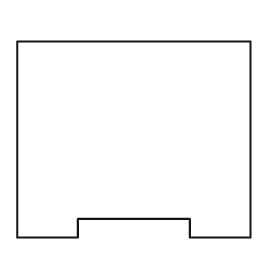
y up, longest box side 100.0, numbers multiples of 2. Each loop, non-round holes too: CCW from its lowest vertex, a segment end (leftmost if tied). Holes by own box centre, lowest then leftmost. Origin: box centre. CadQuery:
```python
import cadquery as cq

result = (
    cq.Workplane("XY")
    .moveTo(-50.0, -42.0)
    .lineTo(-24.0, -42.0)
    .lineTo(-24.0, -34.0)
    .lineTo(24.0, -34.0)
    .lineTo(24.0, -42.0)
    .lineTo(50.0, -42.0)
    .lineTo(50.0, 42.0)
    .lineTo(-50.0, 42.0)
    .close()
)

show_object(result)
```